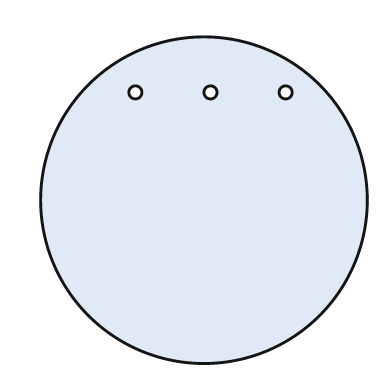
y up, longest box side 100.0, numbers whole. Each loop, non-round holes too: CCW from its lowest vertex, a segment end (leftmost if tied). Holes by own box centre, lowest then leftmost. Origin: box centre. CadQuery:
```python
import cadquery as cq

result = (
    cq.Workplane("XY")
    .moveTo(0.0, 0.0)
    .circle(50.0)
    .moveTo(-21.0, 33.0)
    .circle(2.0)
    .moveTo(2.0, 33.0)
    .circle(2.0)
    .moveTo(25.0, 33.0)
    .circle(2.0)
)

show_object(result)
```